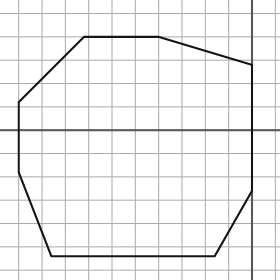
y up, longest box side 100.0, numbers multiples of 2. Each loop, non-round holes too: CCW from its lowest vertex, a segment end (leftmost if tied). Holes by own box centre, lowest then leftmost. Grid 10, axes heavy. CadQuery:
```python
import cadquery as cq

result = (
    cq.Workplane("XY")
    .moveTo(-86.0, -54.0)
    .lineTo(-16.0, -54.0)
    .lineTo(0.0, -26.0)
    .lineTo(0.0, 28.0)
    .lineTo(-40.0, 40.0)
    .lineTo(-72.0, 40.0)
    .lineTo(-100.0, 12.0)
    .lineTo(-100.0, -18.0)
    .close()
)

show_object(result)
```